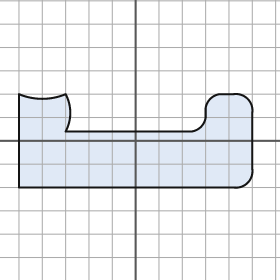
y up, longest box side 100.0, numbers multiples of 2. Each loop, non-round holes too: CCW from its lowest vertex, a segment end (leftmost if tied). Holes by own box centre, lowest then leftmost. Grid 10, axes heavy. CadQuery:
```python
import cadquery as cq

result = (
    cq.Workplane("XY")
    .moveTo(-50.0, -20.0)
    .lineTo(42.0, -20.0)
    .threePointArc((48.0, -18.0), (50.0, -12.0))
    .lineTo(50.0, 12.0)
    .threePointArc((48.0, 18.0), (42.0, 20.0))
    .lineTo(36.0, 20.0)
    .threePointArc((32.0, 18.0), (30.0, 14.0))
    .lineTo(30.0, 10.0)
    .threePointArc((28.0, 6.0), (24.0, 4.0))
    .lineTo(-30.0, 4.0)
    .threePointArc((-28.0, 12.0), (-30.0, 20.0))
    .threePointArc((-40.0, 18.0), (-50.0, 20.0))
    .close()
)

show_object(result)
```